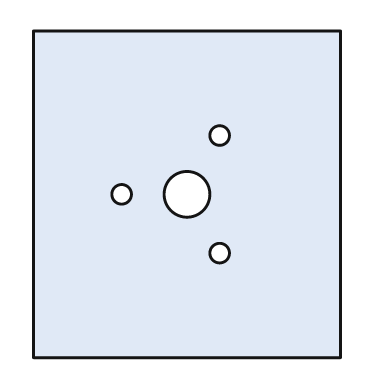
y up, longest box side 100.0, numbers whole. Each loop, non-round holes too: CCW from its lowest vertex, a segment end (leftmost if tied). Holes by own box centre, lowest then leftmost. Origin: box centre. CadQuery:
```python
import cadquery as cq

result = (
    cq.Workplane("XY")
    .moveTo(-47.0, -50.0)
    .lineTo(47.0, -50.0)
    .lineTo(47.0, 50.0)
    .lineTo(-47.0, 50.0)
    .close()
    .moveTo(10.0, -18.0)
    .circle(3.0)
    .moveTo(-20.0, 0.0)
    .circle(3.0)
    .moveTo(0.0, 0.0)
    .circle(7.0)
    .moveTo(10.0, 18.0)
    .circle(3.0)
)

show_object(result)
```